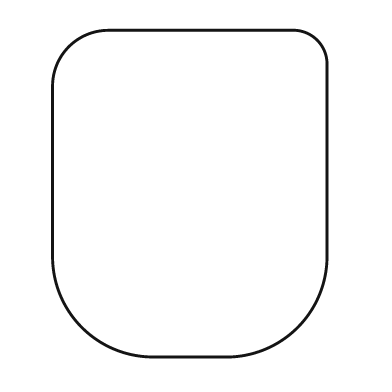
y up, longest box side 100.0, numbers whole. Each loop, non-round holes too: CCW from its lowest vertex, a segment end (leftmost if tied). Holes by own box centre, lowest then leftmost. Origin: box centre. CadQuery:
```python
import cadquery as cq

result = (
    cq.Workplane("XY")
    .moveTo(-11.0, -50.0)
    .lineTo(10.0, -50.0)
    .threePointArc((33.0, -41.0), (42.0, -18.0))
    .lineTo(42.0, 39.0)
    .threePointArc((39.0, 47.0), (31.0, 50.0))
    .lineTo(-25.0, 50.0)
    .threePointArc((-37.0, 45.0), (-42.0, 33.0))
    .lineTo(-42.0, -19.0)
    .threePointArc((-33.0, -41.0), (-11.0, -50.0))
    .close()
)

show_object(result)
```